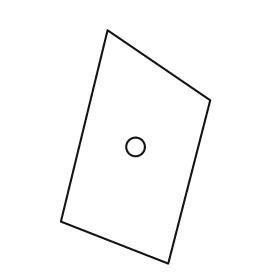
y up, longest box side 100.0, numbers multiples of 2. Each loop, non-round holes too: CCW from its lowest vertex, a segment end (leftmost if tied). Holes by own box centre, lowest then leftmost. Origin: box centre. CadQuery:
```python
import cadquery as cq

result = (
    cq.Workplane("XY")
    .moveTo(14.0, -50.0)
    .lineTo(32.0, 20.0)
    .lineTo(-12.0, 50.0)
    .lineTo(-32.0, -32.0)
    .close()
    .moveTo(0.0, 0.0)
    .circle(4.0)
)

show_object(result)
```